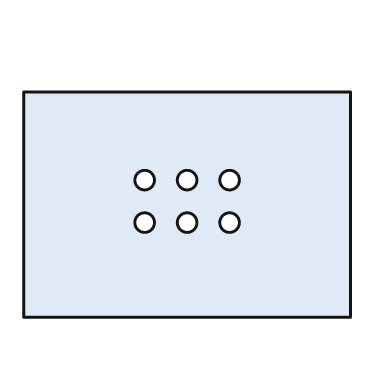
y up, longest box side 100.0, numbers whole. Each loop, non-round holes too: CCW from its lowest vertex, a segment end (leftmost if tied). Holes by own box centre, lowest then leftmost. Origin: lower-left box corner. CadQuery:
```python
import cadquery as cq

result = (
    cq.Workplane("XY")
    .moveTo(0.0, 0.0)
    .lineTo(100.0, 0.0)
    .lineTo(100.0, 69.0)
    .lineTo(0.0, 69.0)
    .close()
    .moveTo(37.0, 29.0)
    .circle(3.0)
    .moveTo(50.0, 29.0)
    .circle(3.0)
    .moveTo(63.0, 29.0)
    .circle(3.0)
    .moveTo(37.0, 42.0)
    .circle(3.0)
    .moveTo(50.0, 42.0)
    .circle(3.0)
    .moveTo(63.0, 42.0)
    .circle(3.0)
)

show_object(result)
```